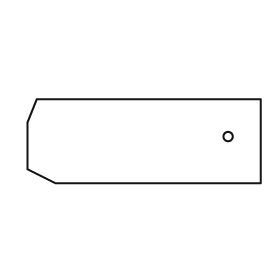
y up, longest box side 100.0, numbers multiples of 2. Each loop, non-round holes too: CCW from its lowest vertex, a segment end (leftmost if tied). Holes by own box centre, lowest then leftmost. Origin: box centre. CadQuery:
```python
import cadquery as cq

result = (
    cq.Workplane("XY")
    .moveTo(-38.0, -18.0)
    .lineTo(50.0, -18.0)
    .lineTo(50.0, 18.0)
    .lineTo(-46.0, 18.0)
    .lineTo(-50.0, 8.0)
    .lineTo(-50.0, -12.0)
    .close()
    .moveTo(36.0, 2.0)
    .circle(2.0)
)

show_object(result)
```